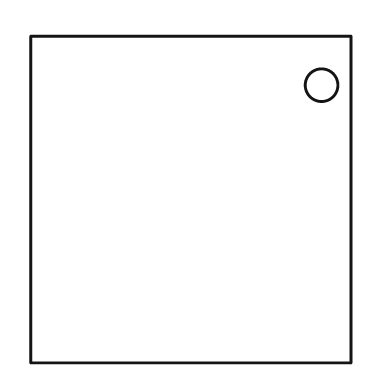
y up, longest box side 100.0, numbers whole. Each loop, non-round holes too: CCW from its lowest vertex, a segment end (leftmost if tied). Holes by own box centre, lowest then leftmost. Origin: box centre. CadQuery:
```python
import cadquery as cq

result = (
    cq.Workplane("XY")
    .moveTo(-49.0, -50.0)
    .lineTo(49.0, -50.0)
    .lineTo(49.0, 50.0)
    .lineTo(-49.0, 50.0)
    .close()
    .moveTo(40.0, 35.0)
    .circle(5.0)
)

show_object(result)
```